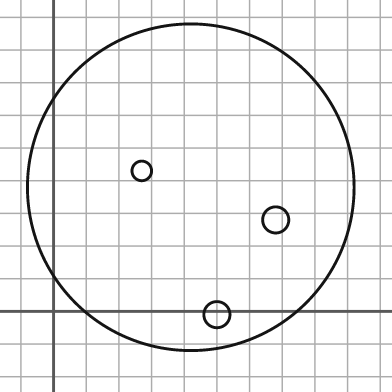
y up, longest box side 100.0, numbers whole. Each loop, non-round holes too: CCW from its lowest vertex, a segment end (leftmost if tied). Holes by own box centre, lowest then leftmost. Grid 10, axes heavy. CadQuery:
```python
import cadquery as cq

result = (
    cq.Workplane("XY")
    .moveTo(42.0, 38.0)
    .circle(50.0)
    .moveTo(50.0, -1.0)
    .circle(4.0)
    .moveTo(68.0, 28.0)
    .circle(4.0)
    .moveTo(27.0, 43.0)
    .circle(3.0)
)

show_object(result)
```